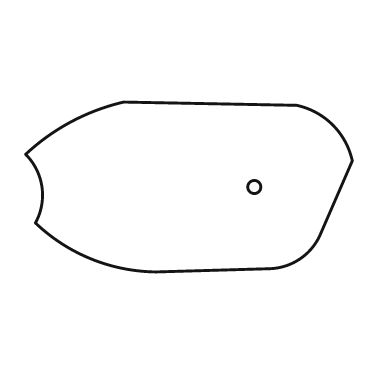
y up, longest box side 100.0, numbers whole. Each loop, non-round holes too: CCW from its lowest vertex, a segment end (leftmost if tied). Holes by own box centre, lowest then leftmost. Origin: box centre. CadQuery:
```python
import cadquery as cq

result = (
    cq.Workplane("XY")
    .moveTo(-10.0, -26.0)
    .lineTo(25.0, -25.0)
    .threePointArc((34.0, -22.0), (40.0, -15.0))
    .lineTo(50.0, 8.0)
    .threePointArc((44.0, 19.0), (33.0, 25.0))
    .lineTo(-20.0, 26.0)
    .threePointArc((-36.0, 20.0), (-50.0, 10.0))
    .threePointArc((-45.0, 0.0), (-47.0, -11.0))
    .threePointArc((-30.0, -22.0), (-10.0, -26.0))
    .close()
    .moveTo(20.0, 0.0)
    .circle(2.0)
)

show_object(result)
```